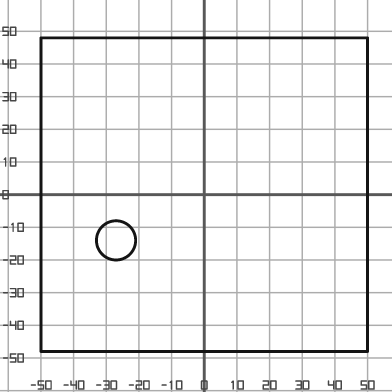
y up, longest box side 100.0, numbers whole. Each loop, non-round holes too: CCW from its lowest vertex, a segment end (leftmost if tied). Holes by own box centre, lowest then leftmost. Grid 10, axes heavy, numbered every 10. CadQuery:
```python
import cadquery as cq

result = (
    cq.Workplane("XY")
    .moveTo(-50.0, -48.0)
    .lineTo(50.0, -48.0)
    .lineTo(50.0, 48.0)
    .lineTo(-50.0, 48.0)
    .close()
    .moveTo(-27.0, -14.0)
    .circle(6.0)
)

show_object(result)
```